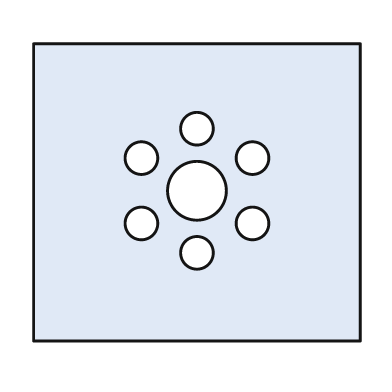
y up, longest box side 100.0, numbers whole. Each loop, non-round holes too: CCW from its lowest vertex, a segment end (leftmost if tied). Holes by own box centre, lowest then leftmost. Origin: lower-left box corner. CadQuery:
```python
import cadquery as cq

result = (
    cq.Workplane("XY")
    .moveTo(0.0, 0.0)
    .lineTo(100.0, 0.0)
    .lineTo(100.0, 91.0)
    .lineTo(0.0, 91.0)
    .close()
    .moveTo(50.0, 27.0)
    .circle(5.0)
    .moveTo(33.0, 36.0)
    .circle(5.0)
    .moveTo(67.0, 36.0)
    .circle(5.0)
    .moveTo(50.0, 46.0)
    .circle(9.0)
    .moveTo(33.0, 56.0)
    .circle(5.0)
    .moveTo(67.0, 56.0)
    .circle(5.0)
    .moveTo(50.0, 65.0)
    .circle(5.0)
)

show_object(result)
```